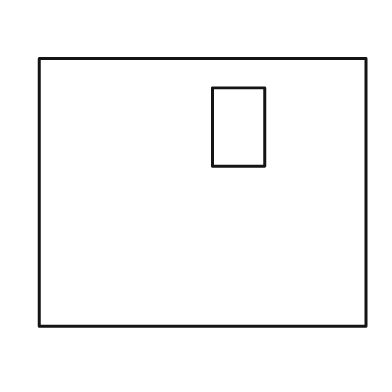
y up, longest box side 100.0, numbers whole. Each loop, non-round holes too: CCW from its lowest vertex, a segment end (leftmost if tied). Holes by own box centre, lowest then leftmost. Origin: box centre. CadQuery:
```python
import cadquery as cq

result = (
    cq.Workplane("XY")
    .moveTo(-50.0, -41.0)
    .lineTo(50.0, -41.0)
    .lineTo(50.0, 41.0)
    .lineTo(-50.0, 41.0)
    .close()
    .moveTo(3.0, 8.0)
    .lineTo(19.0, 8.0)
    .lineTo(19.0, 32.0)
    .lineTo(3.0, 32.0)
    .close()
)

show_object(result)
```